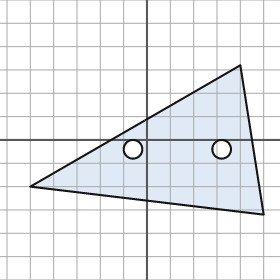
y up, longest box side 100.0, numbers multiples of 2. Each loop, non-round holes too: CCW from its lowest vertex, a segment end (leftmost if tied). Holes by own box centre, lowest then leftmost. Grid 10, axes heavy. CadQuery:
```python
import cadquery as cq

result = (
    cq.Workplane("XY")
    .moveTo(50.0, -32.0)
    .lineTo(40.0, 32.0)
    .lineTo(-50.0, -20.0)
    .close()
    .moveTo(-6.0, -4.0)
    .circle(4.0)
    .moveTo(32.0, -4.0)
    .circle(4.0)
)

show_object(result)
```